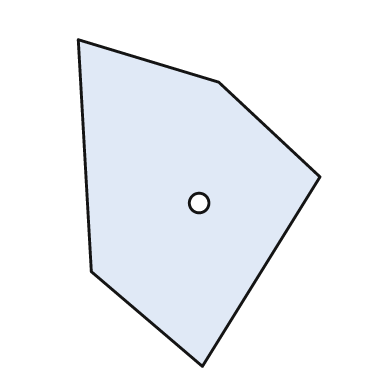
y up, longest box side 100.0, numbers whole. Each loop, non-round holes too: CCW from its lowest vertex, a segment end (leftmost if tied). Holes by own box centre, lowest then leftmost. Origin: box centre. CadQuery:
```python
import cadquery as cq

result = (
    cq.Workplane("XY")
    .moveTo(1.0, -50.0)
    .lineTo(37.0, 8.0)
    .lineTo(6.0, 37.0)
    .lineTo(-37.0, 50.0)
    .lineTo(-33.0, -21.0)
    .close()
    .moveTo(0.0, 0.0)
    .circle(3.0)
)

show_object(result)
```